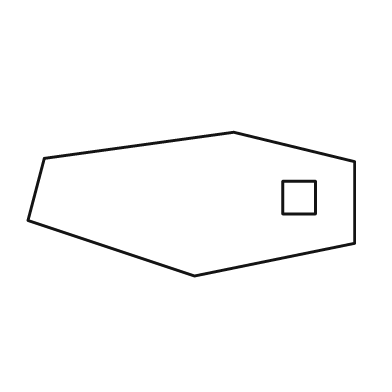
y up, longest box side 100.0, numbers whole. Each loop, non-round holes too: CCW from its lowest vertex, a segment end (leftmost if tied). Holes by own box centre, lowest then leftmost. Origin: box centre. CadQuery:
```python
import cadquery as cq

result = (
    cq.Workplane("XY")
    .moveTo(1.0, -22.0)
    .lineTo(50.0, -12.0)
    .lineTo(50.0, 13.0)
    .lineTo(13.0, 22.0)
    .lineTo(-45.0, 14.0)
    .lineTo(-50.0, -5.0)
    .close()
    .moveTo(28.0, -3.0)
    .lineTo(38.0, -3.0)
    .lineTo(38.0, 7.0)
    .lineTo(28.0, 7.0)
    .close()
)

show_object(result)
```